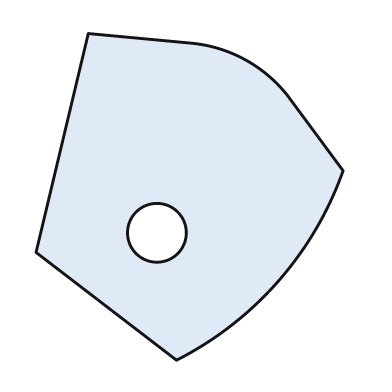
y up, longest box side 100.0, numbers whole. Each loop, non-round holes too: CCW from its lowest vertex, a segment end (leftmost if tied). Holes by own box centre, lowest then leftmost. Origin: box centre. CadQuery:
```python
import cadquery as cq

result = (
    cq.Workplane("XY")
    .moveTo(-4.0, -50.0)
    .threePointArc((27.0, -26.0), (47.0, 8.0))
    .lineTo(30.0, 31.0)
    .threePointArc((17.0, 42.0), (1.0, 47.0))
    .lineTo(-31.0, 50.0)
    .lineTo(-47.0, -17.0)
    .close()
    .moveTo(-10.0, -11.0)
    .circle(9.0)
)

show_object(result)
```